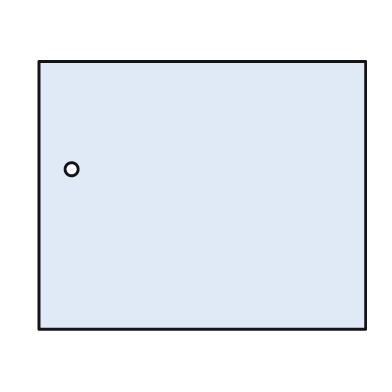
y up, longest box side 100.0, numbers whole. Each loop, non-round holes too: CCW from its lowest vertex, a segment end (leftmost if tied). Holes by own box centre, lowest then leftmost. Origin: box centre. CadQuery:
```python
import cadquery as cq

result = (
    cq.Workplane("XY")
    .moveTo(-50.0, -41.0)
    .lineTo(50.0, -41.0)
    .lineTo(50.0, 41.0)
    .lineTo(-50.0, 41.0)
    .close()
    .moveTo(-40.0, 8.0)
    .circle(2.0)
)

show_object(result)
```